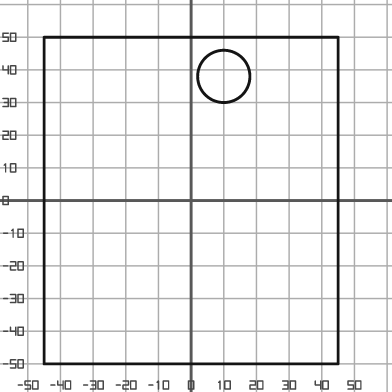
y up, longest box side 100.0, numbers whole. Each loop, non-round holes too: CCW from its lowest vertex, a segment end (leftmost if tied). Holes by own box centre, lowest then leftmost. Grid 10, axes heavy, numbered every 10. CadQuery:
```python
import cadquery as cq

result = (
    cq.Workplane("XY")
    .moveTo(-45.0, -50.0)
    .lineTo(45.0, -50.0)
    .lineTo(45.0, 50.0)
    .lineTo(-45.0, 50.0)
    .close()
    .moveTo(10.0, 38.0)
    .circle(8.0)
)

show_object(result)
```